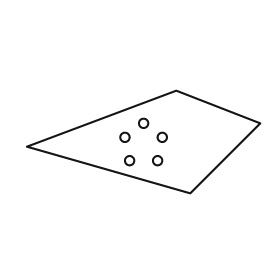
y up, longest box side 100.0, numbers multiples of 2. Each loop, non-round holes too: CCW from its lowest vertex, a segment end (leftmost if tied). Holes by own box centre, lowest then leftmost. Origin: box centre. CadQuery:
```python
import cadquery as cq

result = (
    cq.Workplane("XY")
    .moveTo(20.0, -22.0)
    .lineTo(50.0, 8.0)
    .lineTo(14.0, 22.0)
    .lineTo(-50.0, -2.0)
    .close()
    .moveTo(-6.0, -8.0)
    .circle(2.0)
    .moveTo(6.0, -8.0)
    .circle(2.0)
    .moveTo(-8.0, 2.0)
    .circle(2.0)
    .moveTo(8.0, 2.0)
    .circle(2.0)
    .moveTo(0.0, 8.0)
    .circle(2.0)
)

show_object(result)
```